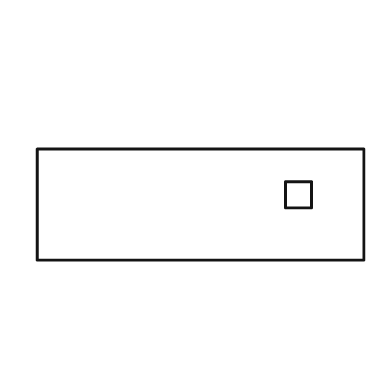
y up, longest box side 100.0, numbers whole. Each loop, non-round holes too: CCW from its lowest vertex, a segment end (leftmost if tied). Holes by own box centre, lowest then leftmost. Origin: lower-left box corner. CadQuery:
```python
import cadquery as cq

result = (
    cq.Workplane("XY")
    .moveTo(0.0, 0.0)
    .lineTo(100.0, 0.0)
    .lineTo(100.0, 34.0)
    .lineTo(0.0, 34.0)
    .close()
    .moveTo(76.0, 16.0)
    .lineTo(84.0, 16.0)
    .lineTo(84.0, 24.0)
    .lineTo(76.0, 24.0)
    .close()
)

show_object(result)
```